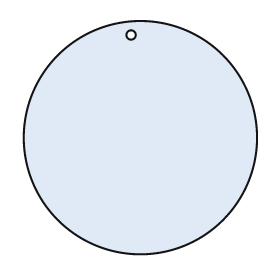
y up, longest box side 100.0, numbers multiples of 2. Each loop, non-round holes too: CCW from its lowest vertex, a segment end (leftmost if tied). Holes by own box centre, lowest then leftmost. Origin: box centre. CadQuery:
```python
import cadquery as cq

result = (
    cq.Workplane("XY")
    .moveTo(0.0, 0.0)
    .circle(50.0)
    .moveTo(-4.0, 44.0)
    .circle(2.0)
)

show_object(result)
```